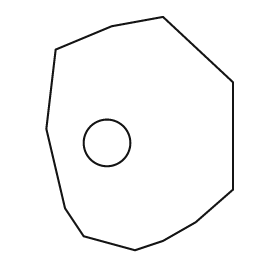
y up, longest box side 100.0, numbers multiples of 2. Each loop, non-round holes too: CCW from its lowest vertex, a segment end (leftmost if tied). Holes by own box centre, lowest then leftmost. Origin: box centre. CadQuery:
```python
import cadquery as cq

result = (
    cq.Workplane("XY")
    .moveTo(-2.0, -50.0)
    .lineTo(10.0, -46.0)
    .lineTo(24.0, -38.0)
    .lineTo(40.0, -24.0)
    .lineTo(40.0, 22.0)
    .lineTo(10.0, 50.0)
    .lineTo(-12.0, 46.0)
    .lineTo(-36.0, 36.0)
    .lineTo(-40.0, 2.0)
    .lineTo(-32.0, -32.0)
    .lineTo(-24.0, -44.0)
    .close()
    .moveTo(-14.0, -4.0)
    .circle(10.0)
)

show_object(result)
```